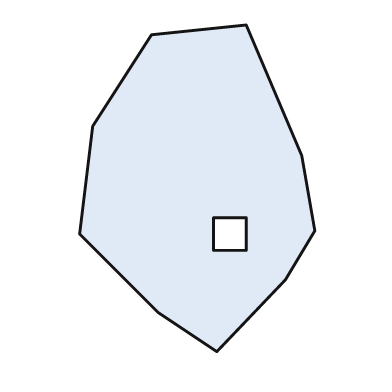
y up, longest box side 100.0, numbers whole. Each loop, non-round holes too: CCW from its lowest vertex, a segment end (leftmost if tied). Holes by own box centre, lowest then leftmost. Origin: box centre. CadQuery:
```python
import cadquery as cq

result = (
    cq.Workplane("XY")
    .moveTo(6.0, -50.0)
    .lineTo(27.0, -28.0)
    .lineTo(36.0, -13.0)
    .lineTo(32.0, 10.0)
    .lineTo(15.0, 50.0)
    .lineTo(-14.0, 47.0)
    .lineTo(-32.0, 19.0)
    .lineTo(-36.0, -14.0)
    .lineTo(-12.0, -38.0)
    .close()
    .moveTo(5.0, -19.0)
    .lineTo(15.0, -19.0)
    .lineTo(15.0, -9.0)
    .lineTo(5.0, -9.0)
    .close()
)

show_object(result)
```